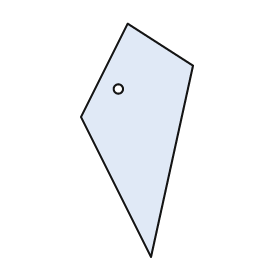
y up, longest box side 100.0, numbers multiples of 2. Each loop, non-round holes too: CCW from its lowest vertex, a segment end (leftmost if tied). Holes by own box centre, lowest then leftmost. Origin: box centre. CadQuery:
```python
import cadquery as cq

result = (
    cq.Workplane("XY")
    .moveTo(6.0, -50.0)
    .lineTo(24.0, 32.0)
    .lineTo(-4.0, 50.0)
    .lineTo(-24.0, 10.0)
    .close()
    .moveTo(-8.0, 22.0)
    .circle(2.0)
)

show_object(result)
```